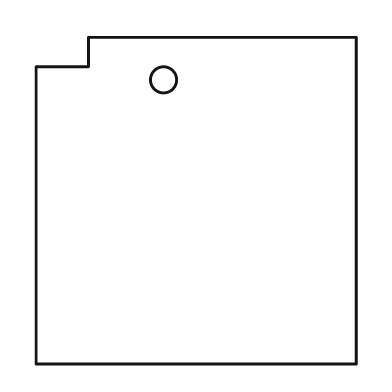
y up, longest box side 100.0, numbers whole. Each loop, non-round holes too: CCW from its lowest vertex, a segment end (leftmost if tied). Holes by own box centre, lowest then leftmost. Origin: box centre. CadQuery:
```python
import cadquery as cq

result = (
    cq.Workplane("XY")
    .moveTo(-49.0, -50.0)
    .lineTo(49.0, -50.0)
    .lineTo(49.0, 50.0)
    .lineTo(-33.0, 50.0)
    .lineTo(-33.0, 41.0)
    .lineTo(-49.0, 41.0)
    .close()
    .moveTo(-10.0, 37.0)
    .circle(4.0)
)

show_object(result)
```